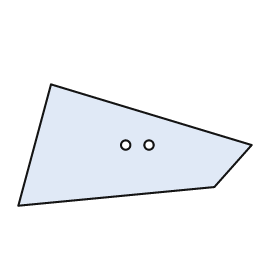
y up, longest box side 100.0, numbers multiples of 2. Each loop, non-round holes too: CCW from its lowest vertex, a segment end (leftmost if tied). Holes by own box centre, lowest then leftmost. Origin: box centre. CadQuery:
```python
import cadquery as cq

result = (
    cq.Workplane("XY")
    .moveTo(-50.0, -26.0)
    .lineTo(34.0, -18.0)
    .lineTo(50.0, 0.0)
    .lineTo(-36.0, 26.0)
    .close()
    .moveTo(-4.0, 0.0)
    .circle(2.0)
    .moveTo(6.0, 0.0)
    .circle(2.0)
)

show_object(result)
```